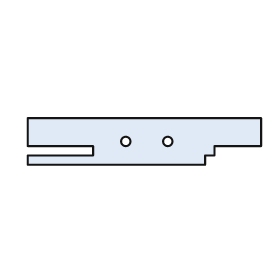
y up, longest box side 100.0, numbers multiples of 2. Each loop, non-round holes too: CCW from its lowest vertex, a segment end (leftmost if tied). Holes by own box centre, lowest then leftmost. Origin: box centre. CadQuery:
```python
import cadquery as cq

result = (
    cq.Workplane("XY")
    .moveTo(-50.0, -10.0)
    .lineTo(26.0, -10.0)
    .lineTo(26.0, -6.0)
    .lineTo(30.0, -6.0)
    .lineTo(30.0, -2.0)
    .lineTo(50.0, -2.0)
    .lineTo(50.0, 10.0)
    .lineTo(-50.0, 10.0)
    .lineTo(-50.0, -2.0)
    .lineTo(-22.0, -2.0)
    .lineTo(-22.0, -6.0)
    .lineTo(-50.0, -6.0)
    .close()
    .moveTo(-8.0, 0.0)
    .circle(2.0)
    .moveTo(10.0, 0.0)
    .circle(2.0)
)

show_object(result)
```